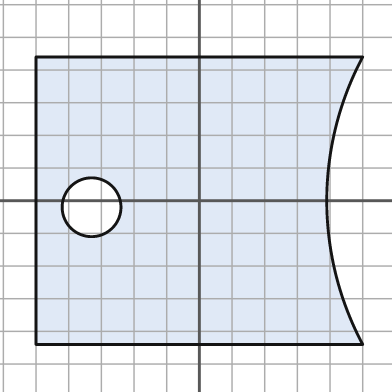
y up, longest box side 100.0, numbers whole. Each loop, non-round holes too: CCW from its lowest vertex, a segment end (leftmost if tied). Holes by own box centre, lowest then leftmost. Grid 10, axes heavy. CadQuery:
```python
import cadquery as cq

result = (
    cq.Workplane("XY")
    .moveTo(-50.0, -44.0)
    .lineTo(50.0, -44.0)
    .threePointArc((39.0, 0.0), (50.0, 44.0))
    .lineTo(-50.0, 44.0)
    .close()
    .moveTo(-33.0, -2.0)
    .circle(9.0)
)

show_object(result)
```